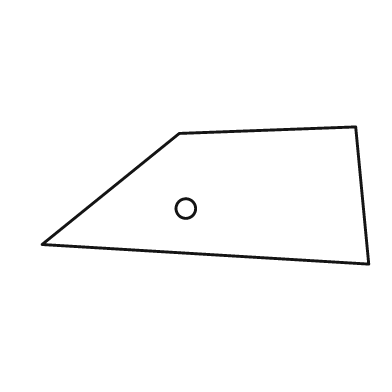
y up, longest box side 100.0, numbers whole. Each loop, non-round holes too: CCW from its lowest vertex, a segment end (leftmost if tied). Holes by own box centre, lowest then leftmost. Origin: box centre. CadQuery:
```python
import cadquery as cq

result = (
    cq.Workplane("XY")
    .moveTo(50.0, -21.0)
    .lineTo(46.0, 21.0)
    .lineTo(-8.0, 19.0)
    .lineTo(-50.0, -15.0)
    .close()
    .moveTo(-6.0, -4.0)
    .circle(3.0)
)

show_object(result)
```